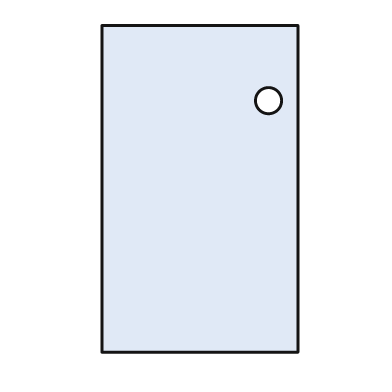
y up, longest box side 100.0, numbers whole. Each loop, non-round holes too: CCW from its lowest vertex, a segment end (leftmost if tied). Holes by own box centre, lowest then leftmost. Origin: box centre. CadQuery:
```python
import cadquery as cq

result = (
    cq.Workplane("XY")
    .moveTo(-30.0, -50.0)
    .lineTo(30.0, -50.0)
    .lineTo(30.0, 50.0)
    .lineTo(-30.0, 50.0)
    .close()
    .moveTo(21.0, 27.0)
    .circle(4.0)
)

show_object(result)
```